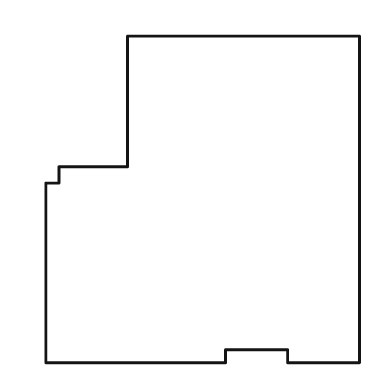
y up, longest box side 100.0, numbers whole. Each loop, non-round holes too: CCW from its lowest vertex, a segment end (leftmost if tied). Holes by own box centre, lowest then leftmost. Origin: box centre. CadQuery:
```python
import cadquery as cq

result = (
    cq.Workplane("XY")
    .moveTo(-48.0, -50.0)
    .lineTo(7.0, -50.0)
    .lineTo(7.0, -46.0)
    .lineTo(26.0, -46.0)
    .lineTo(26.0, -50.0)
    .lineTo(48.0, -50.0)
    .lineTo(48.0, 50.0)
    .lineTo(-23.0, 50.0)
    .lineTo(-23.0, 10.0)
    .lineTo(-44.0, 10.0)
    .lineTo(-44.0, 5.0)
    .lineTo(-48.0, 5.0)
    .close()
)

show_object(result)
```